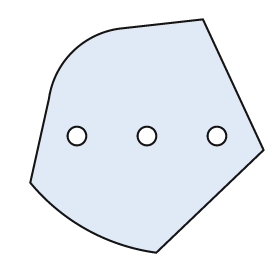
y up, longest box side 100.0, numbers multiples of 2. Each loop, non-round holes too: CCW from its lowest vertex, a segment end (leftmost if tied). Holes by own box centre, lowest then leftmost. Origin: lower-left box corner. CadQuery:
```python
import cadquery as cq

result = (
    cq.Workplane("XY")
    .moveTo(54.0, 0.0)
    .lineTo(100.0, 44.0)
    .lineTo(74.0, 100.0)
    .lineTo(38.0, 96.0)
    .threePointArc((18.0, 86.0), (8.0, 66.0))
    .lineTo(0.0, 30.0)
    .threePointArc((24.0, 10.0), (54.0, 0.0))
    .close()
    .moveTo(20.0, 50.0)
    .circle(4.0)
    .moveTo(50.0, 50.0)
    .circle(4.0)
    .moveTo(80.0, 50.0)
    .circle(4.0)
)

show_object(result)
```